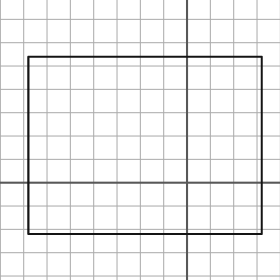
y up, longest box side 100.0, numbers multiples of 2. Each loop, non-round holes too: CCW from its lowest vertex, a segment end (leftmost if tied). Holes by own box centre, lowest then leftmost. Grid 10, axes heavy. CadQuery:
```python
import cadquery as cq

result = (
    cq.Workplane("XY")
    .moveTo(-68.0, -22.0)
    .lineTo(32.0, -22.0)
    .lineTo(32.0, 54.0)
    .lineTo(-68.0, 54.0)
    .close()
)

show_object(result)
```